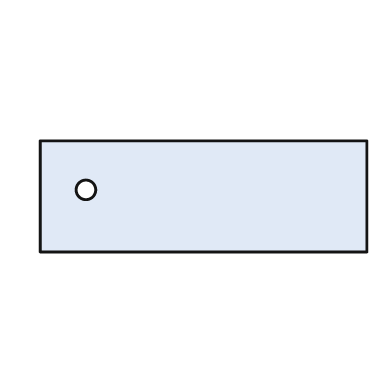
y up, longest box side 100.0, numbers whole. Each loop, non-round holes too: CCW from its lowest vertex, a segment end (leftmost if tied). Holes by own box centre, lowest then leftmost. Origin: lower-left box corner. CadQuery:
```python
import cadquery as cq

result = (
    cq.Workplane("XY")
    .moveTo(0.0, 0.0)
    .lineTo(100.0, 0.0)
    .lineTo(100.0, 34.0)
    .lineTo(0.0, 34.0)
    .close()
    .moveTo(14.0, 19.0)
    .circle(3.0)
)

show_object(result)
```